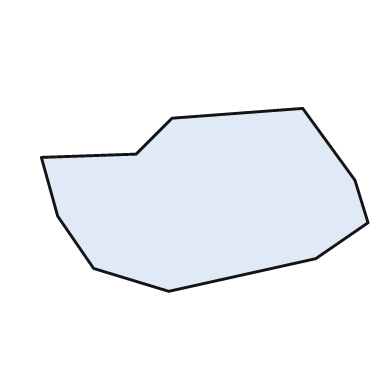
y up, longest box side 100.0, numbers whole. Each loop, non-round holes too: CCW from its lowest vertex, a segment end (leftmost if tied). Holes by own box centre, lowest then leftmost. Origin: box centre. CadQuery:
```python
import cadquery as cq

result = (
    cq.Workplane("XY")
    .moveTo(-11.0, -28.0)
    .lineTo(34.0, -18.0)
    .lineTo(50.0, -7.0)
    .lineTo(46.0, 6.0)
    .lineTo(30.0, 28.0)
    .lineTo(-10.0, 25.0)
    .lineTo(-21.0, 14.0)
    .lineTo(-50.0, 13.0)
    .lineTo(-45.0, -5.0)
    .lineTo(-34.0, -21.0)
    .close()
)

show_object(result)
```